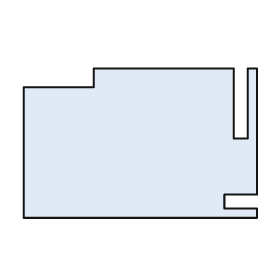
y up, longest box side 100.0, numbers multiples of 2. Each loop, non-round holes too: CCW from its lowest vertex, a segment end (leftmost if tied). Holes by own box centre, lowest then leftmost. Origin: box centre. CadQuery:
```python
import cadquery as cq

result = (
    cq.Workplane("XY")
    .moveTo(-50.0, -32.0)
    .lineTo(50.0, -32.0)
    .lineTo(50.0, -28.0)
    .lineTo(36.0, -28.0)
    .lineTo(36.0, -22.0)
    .lineTo(50.0, -22.0)
    .lineTo(50.0, 32.0)
    .lineTo(46.0, 32.0)
    .lineTo(46.0, 2.0)
    .lineTo(40.0, 2.0)
    .lineTo(40.0, 32.0)
    .lineTo(-20.0, 32.0)
    .lineTo(-20.0, 24.0)
    .lineTo(-50.0, 24.0)
    .close()
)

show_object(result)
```